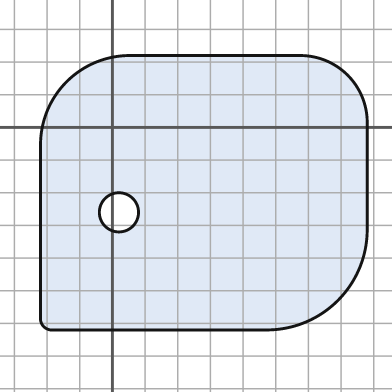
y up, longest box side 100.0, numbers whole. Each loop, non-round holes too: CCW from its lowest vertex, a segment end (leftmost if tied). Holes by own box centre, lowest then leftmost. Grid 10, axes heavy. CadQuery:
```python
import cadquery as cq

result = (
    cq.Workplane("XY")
    .moveTo(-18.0, -62.0)
    .lineTo(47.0, -62.0)
    .threePointArc((69.0, -53.0), (78.0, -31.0))
    .lineTo(78.0, 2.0)
    .threePointArc((72.0, 16.0), (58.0, 22.0))
    .lineTo(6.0, 22.0)
    .threePointArc((-14.0, 14.0), (-22.0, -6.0))
    .lineTo(-22.0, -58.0)
    .threePointArc((-21.0, -61.0), (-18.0, -62.0))
    .close()
    .moveTo(2.0, -26.0)
    .circle(6.0)
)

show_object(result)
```